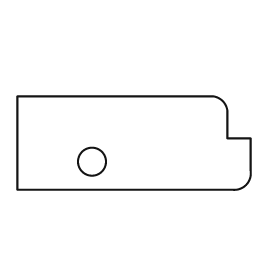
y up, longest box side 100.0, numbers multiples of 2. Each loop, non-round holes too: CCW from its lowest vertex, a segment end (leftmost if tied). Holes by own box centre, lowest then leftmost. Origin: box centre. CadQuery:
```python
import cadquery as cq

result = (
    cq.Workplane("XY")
    .moveTo(-50.0, -20.0)
    .lineTo(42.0, -20.0)
    .threePointArc((48.0, -18.0), (50.0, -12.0))
    .lineTo(50.0, 2.0)
    .lineTo(40.0, 2.0)
    .lineTo(40.0, 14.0)
    .threePointArc((38.0, 18.0), (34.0, 20.0))
    .lineTo(-50.0, 20.0)
    .close()
    .moveTo(-18.0, -8.0)
    .circle(6.0)
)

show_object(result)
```